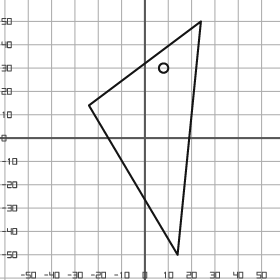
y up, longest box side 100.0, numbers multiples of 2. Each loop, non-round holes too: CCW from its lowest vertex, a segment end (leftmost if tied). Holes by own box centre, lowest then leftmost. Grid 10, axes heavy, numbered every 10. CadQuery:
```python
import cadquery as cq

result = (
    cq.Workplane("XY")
    .moveTo(14.0, -50.0)
    .lineTo(24.0, 50.0)
    .lineTo(-24.0, 14.0)
    .close()
    .moveTo(8.0, 30.0)
    .circle(2.0)
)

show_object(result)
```